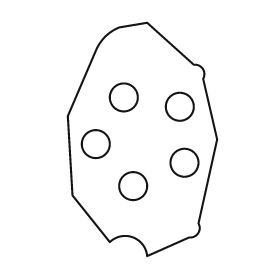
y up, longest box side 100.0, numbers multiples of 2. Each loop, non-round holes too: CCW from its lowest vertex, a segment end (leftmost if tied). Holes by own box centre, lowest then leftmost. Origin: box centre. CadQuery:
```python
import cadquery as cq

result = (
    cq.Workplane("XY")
    .moveTo(2.0, -50.0)
    .lineTo(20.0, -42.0)
    .threePointArc((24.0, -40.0), (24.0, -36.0))
    .lineTo(32.0, 0.0)
    .lineTo(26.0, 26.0)
    .threePointArc((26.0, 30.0), (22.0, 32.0))
    .lineTo(2.0, 50.0)
    .lineTo(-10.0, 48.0)
    .threePointArc((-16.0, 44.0), (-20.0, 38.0))
    .lineTo(-32.0, 10.0)
    .lineTo(-30.0, -24.0)
    .lineTo(-14.0, -44.0)
    .threePointArc((-4.0, -42.0), (2.0, -50.0))
    .close()
    .moveTo(-4.0, -20.0)
    .circle(6.0)
    .moveTo(18.0, -10.0)
    .circle(6.0)
    .moveTo(-20.0, -2.0)
    .circle(6.0)
    .moveTo(16.0, 14.0)
    .circle(6.0)
    .moveTo(-8.0, 18.0)
    .circle(6.0)
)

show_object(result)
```